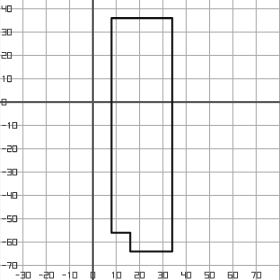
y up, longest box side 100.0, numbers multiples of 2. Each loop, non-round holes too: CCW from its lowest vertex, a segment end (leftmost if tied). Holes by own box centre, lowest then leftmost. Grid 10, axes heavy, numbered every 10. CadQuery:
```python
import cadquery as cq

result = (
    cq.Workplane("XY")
    .moveTo(16.0, -64.0)
    .lineTo(34.0, -64.0)
    .lineTo(34.0, 36.0)
    .lineTo(8.0, 36.0)
    .lineTo(8.0, -56.0)
    .lineTo(16.0, -56.0)
    .close()
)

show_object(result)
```